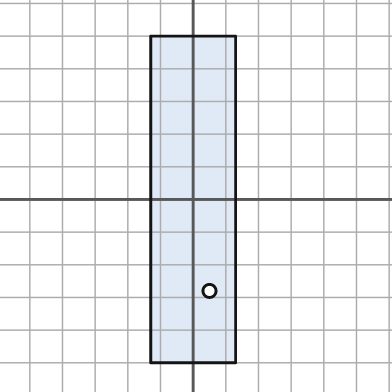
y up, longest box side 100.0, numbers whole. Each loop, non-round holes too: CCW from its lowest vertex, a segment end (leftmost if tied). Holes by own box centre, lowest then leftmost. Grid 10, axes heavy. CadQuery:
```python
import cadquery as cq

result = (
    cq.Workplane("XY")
    .moveTo(-13.0, -50.0)
    .lineTo(13.0, -50.0)
    .lineTo(13.0, 50.0)
    .lineTo(-13.0, 50.0)
    .close()
    .moveTo(5.0, -28.0)
    .circle(2.0)
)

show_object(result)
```